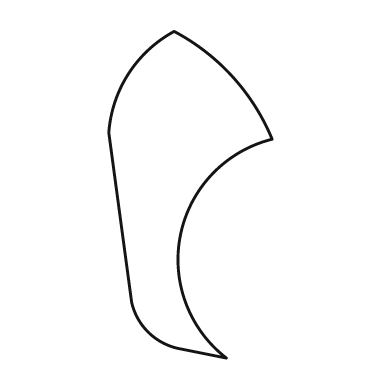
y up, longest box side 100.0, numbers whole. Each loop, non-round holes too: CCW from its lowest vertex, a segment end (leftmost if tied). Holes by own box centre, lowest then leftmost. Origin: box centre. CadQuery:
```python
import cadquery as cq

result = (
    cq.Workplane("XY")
    .moveTo(11.0, -50.0)
    .threePointArc((-3.0, -12.0), (25.0, 17.0))
    .threePointArc((13.0, 36.0), (-5.0, 50.0))
    .threePointArc((-19.0, 37.0), (-25.0, 19.0))
    .lineTo(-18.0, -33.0)
    .threePointArc((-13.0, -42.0), (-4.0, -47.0))
    .close()
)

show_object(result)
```